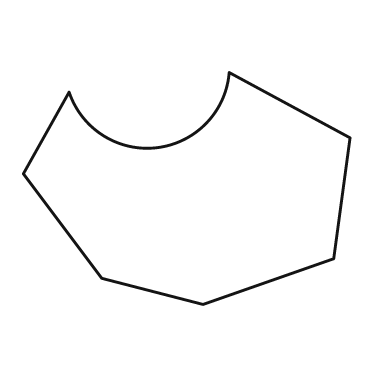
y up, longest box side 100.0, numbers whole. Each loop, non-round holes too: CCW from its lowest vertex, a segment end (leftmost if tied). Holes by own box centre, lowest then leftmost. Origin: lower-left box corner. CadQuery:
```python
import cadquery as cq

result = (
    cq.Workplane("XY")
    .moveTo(55.0, 0.0)
    .lineTo(95.0, 14.0)
    .lineTo(100.0, 51.0)
    .lineTo(63.0, 71.0)
    .threePointArc((41.0, 48.0), (14.0, 65.0))
    .lineTo(0.0, 40.0)
    .lineTo(24.0, 8.0)
    .close()
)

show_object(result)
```